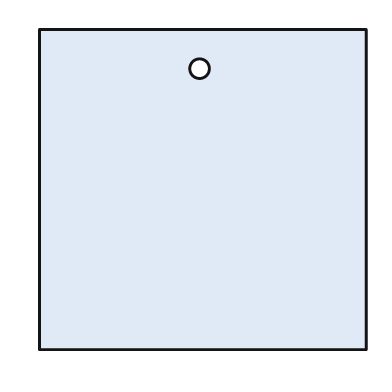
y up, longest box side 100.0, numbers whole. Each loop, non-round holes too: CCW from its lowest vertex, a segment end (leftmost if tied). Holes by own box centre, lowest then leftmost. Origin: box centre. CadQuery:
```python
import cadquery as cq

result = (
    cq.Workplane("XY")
    .moveTo(-50.0, -49.0)
    .lineTo(50.0, -49.0)
    .lineTo(50.0, 49.0)
    .lineTo(-50.0, 49.0)
    .close()
    .moveTo(-1.0, 37.0)
    .circle(3.0)
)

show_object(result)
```